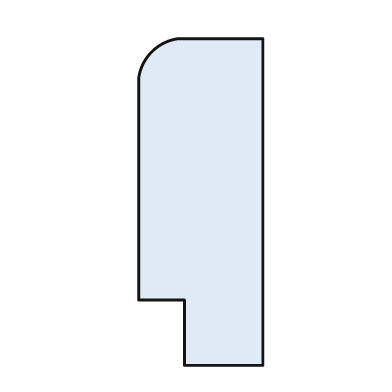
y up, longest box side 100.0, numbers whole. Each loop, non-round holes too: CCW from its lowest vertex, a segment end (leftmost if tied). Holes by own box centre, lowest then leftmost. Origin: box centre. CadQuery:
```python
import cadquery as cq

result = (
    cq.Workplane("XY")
    .moveTo(-5.0, -50.0)
    .lineTo(19.0, -50.0)
    .lineTo(19.0, 50.0)
    .lineTo(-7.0, 50.0)
    .threePointArc((-15.0, 46.0), (-19.0, 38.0))
    .lineTo(-19.0, -30.0)
    .lineTo(-5.0, -30.0)
    .close()
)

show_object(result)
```